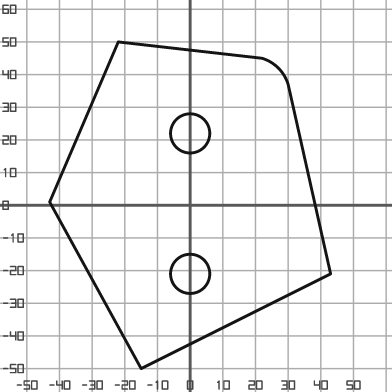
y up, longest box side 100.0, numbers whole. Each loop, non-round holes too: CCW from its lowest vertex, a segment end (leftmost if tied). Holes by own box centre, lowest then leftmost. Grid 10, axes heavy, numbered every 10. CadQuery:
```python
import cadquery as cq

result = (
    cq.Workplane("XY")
    .moveTo(-15.0, -50.0)
    .lineTo(43.0, -21.0)
    .lineTo(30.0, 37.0)
    .threePointArc((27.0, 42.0), (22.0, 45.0))
    .lineTo(-22.0, 50.0)
    .lineTo(-43.0, 1.0)
    .close()
    .moveTo(0.0, -21.0)
    .circle(6.0)
    .moveTo(0.0, 22.0)
    .circle(6.0)
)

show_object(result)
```